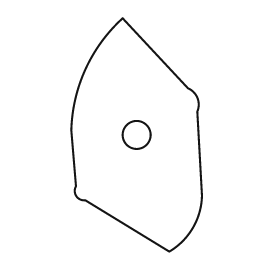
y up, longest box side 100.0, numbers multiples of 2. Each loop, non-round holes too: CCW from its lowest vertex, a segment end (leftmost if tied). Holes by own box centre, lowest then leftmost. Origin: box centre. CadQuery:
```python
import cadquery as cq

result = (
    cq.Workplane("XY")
    .moveTo(14.0, -50.0)
    .threePointArc((24.0, -40.0), (28.0, -26.0))
    .lineTo(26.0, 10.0)
    .threePointArc((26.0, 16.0), (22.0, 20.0))
    .lineTo(-6.0, 50.0)
    .threePointArc((-22.0, 28.0), (-28.0, 2.0))
    .lineTo(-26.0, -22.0)
    .threePointArc((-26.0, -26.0), (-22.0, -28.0))
    .close()
    .moveTo(0.0, 0.0)
    .circle(6.0)
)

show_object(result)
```